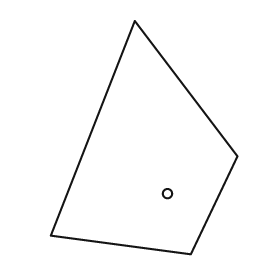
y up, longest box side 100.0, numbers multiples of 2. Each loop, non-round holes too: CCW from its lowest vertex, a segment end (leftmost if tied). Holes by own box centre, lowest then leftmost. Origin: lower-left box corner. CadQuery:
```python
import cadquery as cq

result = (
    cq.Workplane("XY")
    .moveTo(60.0, 0.0)
    .lineTo(80.0, 42.0)
    .lineTo(36.0, 100.0)
    .lineTo(0.0, 8.0)
    .close()
    .moveTo(50.0, 26.0)
    .circle(2.0)
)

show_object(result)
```